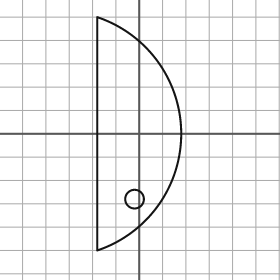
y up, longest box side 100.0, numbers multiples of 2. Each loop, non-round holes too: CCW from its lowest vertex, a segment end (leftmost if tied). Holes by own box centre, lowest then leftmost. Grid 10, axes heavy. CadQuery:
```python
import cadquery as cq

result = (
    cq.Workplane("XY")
    .moveTo(-18.0, -50.0)
    .threePointArc((18.0, 0.0), (-18.0, 50.0))
    .close()
    .moveTo(-2.0, -28.0)
    .circle(4.0)
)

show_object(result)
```